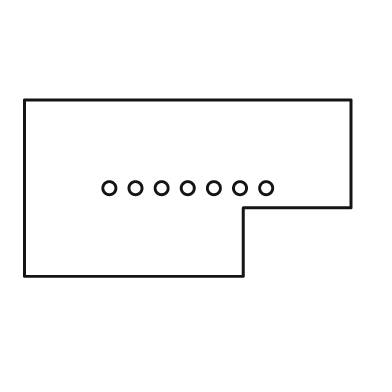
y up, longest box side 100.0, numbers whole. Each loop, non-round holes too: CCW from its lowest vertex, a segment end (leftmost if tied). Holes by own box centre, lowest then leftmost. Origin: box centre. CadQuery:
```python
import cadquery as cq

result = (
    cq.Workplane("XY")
    .moveTo(-50.0, -27.0)
    .lineTo(17.0, -27.0)
    .lineTo(17.0, -6.0)
    .lineTo(50.0, -6.0)
    .lineTo(50.0, 27.0)
    .lineTo(-50.0, 27.0)
    .close()
    .moveTo(-24.0, 0.0)
    .circle(2.0)
    .moveTo(-16.0, 0.0)
    .circle(2.0)
    .moveTo(-8.0, 0.0)
    .circle(2.0)
    .moveTo(0.0, 0.0)
    .circle(2.0)
    .moveTo(8.0, 0.0)
    .circle(2.0)
    .moveTo(16.0, 0.0)
    .circle(2.0)
    .moveTo(24.0, 0.0)
    .circle(2.0)
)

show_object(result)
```